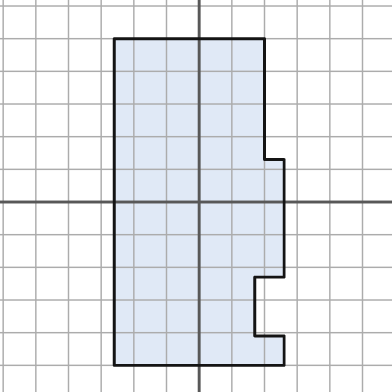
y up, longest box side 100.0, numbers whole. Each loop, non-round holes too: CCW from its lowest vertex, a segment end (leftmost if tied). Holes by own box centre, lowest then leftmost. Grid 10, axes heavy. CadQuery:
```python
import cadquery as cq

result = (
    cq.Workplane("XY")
    .moveTo(-26.0, -50.0)
    .lineTo(26.0, -50.0)
    .lineTo(26.0, -41.0)
    .lineTo(17.0, -41.0)
    .lineTo(17.0, -23.0)
    .lineTo(26.0, -23.0)
    .lineTo(26.0, 13.0)
    .lineTo(20.0, 13.0)
    .lineTo(20.0, 50.0)
    .lineTo(-26.0, 50.0)
    .close()
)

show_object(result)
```